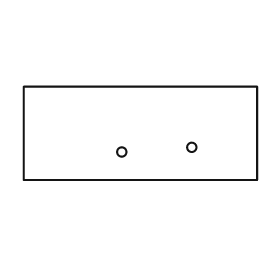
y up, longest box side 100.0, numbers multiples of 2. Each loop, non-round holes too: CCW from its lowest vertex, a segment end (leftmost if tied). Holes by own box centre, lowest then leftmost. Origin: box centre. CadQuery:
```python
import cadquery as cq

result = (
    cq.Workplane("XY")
    .moveTo(-50.0, -20.0)
    .lineTo(50.0, -20.0)
    .lineTo(50.0, 20.0)
    .lineTo(-50.0, 20.0)
    .close()
    .moveTo(-8.0, -8.0)
    .circle(2.0)
    .moveTo(22.0, -6.0)
    .circle(2.0)
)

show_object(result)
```